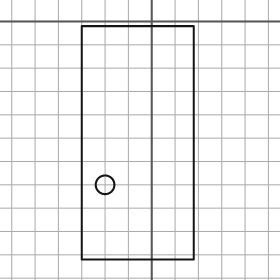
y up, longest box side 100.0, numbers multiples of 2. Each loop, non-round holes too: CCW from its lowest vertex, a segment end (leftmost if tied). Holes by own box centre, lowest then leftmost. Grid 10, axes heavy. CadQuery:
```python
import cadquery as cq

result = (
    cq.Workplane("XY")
    .moveTo(-30.0, -102.0)
    .lineTo(18.0, -102.0)
    .lineTo(18.0, -2.0)
    .lineTo(-30.0, -2.0)
    .close()
    .moveTo(-20.0, -70.0)
    .circle(4.0)
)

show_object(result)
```